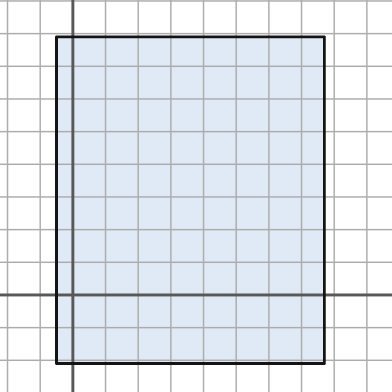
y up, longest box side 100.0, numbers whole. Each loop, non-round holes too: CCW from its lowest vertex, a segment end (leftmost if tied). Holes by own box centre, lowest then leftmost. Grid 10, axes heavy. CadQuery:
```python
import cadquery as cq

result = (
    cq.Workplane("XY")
    .moveTo(-5.0, -21.0)
    .lineTo(77.0, -21.0)
    .lineTo(77.0, 79.0)
    .lineTo(-5.0, 79.0)
    .close()
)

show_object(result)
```